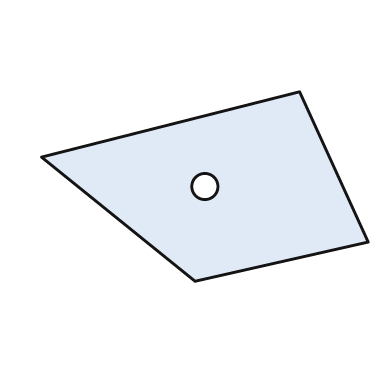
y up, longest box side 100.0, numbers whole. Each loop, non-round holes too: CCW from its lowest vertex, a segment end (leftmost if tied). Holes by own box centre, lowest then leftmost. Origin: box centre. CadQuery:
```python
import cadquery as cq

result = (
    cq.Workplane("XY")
    .moveTo(-3.0, -29.0)
    .lineTo(50.0, -17.0)
    .lineTo(29.0, 29.0)
    .lineTo(-50.0, 9.0)
    .close()
    .moveTo(0.0, 0.0)
    .circle(4.0)
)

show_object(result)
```